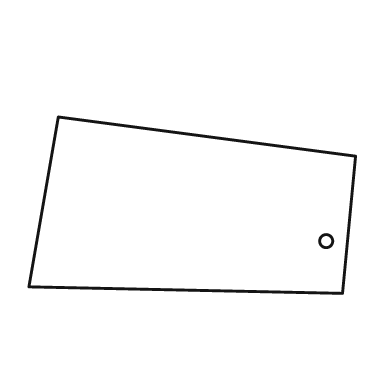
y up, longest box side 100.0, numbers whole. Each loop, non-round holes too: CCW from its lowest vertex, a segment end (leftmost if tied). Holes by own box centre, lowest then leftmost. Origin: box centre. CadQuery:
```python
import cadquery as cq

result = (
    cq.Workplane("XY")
    .moveTo(46.0, -27.0)
    .lineTo(50.0, 15.0)
    .lineTo(-41.0, 27.0)
    .lineTo(-50.0, -25.0)
    .close()
    .moveTo(41.0, -11.0)
    .circle(2.0)
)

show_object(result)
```